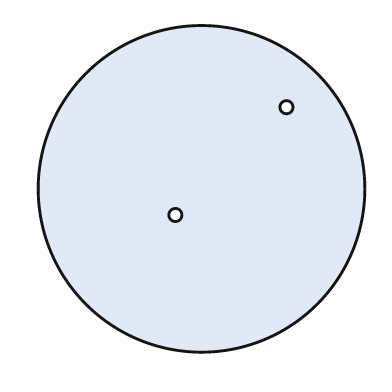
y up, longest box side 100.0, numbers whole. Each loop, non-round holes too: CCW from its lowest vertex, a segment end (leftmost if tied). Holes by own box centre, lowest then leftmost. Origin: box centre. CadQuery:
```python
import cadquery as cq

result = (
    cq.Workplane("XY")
    .moveTo(0.0, 0.0)
    .circle(50.0)
    .moveTo(-8.0, -8.0)
    .circle(2.0)
    .moveTo(26.0, 25.0)
    .circle(2.0)
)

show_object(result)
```